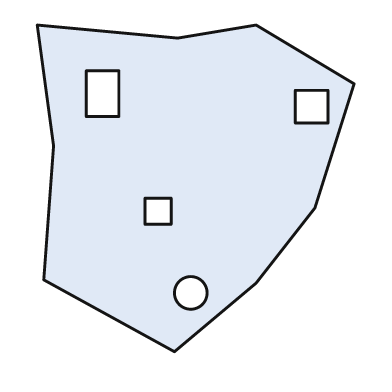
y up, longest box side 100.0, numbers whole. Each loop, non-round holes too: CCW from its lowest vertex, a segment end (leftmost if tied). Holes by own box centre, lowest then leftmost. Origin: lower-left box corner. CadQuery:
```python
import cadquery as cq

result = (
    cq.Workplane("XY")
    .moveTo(42.0, 0.0)
    .lineTo(67.0, 21.0)
    .lineTo(85.0, 44.0)
    .lineTo(97.0, 82.0)
    .lineTo(67.0, 100.0)
    .lineTo(43.0, 96.0)
    .lineTo(0.0, 100.0)
    .lineTo(5.0, 63.0)
    .lineTo(2.0, 22.0)
    .close()
    .moveTo(47.0, 18.0)
    .circle(5.0)
    .moveTo(33.0, 39.0)
    .lineTo(41.0, 39.0)
    .lineTo(41.0, 47.0)
    .lineTo(33.0, 47.0)
    .close()
    .moveTo(79.0, 70.0)
    .lineTo(89.0, 70.0)
    .lineTo(89.0, 80.0)
    .lineTo(79.0, 80.0)
    .close()
    .moveTo(15.0, 72.0)
    .lineTo(25.0, 72.0)
    .lineTo(25.0, 86.0)
    .lineTo(15.0, 86.0)
    .close()
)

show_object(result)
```